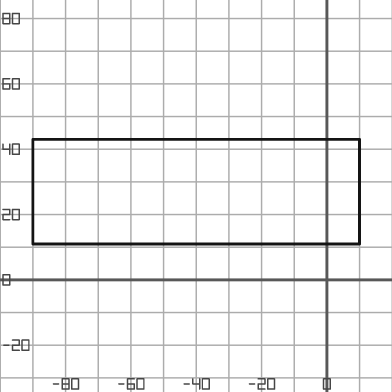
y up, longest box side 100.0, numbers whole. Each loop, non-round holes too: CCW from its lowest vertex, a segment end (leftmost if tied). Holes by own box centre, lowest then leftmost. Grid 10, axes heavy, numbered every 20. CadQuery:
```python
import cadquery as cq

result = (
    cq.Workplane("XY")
    .moveTo(-90.0, 11.0)
    .lineTo(10.0, 11.0)
    .lineTo(10.0, 43.0)
    .lineTo(-90.0, 43.0)
    .close()
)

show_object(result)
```